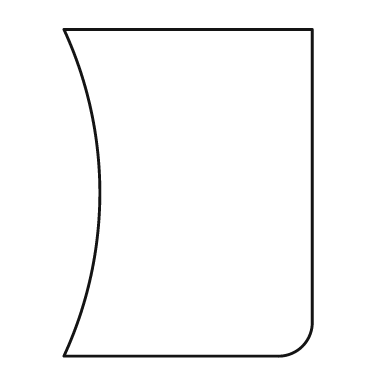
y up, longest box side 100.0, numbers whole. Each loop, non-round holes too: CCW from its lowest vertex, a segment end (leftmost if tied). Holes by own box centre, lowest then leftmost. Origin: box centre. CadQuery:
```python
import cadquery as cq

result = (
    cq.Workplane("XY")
    .moveTo(-38.0, -50.0)
    .lineTo(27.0, -50.0)
    .threePointArc((35.0, -47.0), (38.0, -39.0))
    .lineTo(38.0, 50.0)
    .lineTo(-38.0, 50.0)
    .threePointArc((-27.0, 0.0), (-38.0, -50.0))
    .close()
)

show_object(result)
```